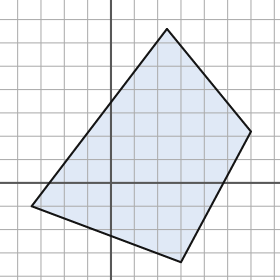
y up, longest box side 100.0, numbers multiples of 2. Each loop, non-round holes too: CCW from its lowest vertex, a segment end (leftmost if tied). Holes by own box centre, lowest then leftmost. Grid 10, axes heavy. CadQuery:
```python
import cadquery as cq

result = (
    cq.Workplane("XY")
    .moveTo(30.0, -34.0)
    .lineTo(60.0, 22.0)
    .lineTo(24.0, 66.0)
    .lineTo(-34.0, -10.0)
    .close()
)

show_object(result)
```